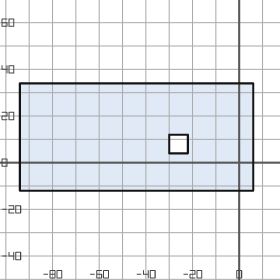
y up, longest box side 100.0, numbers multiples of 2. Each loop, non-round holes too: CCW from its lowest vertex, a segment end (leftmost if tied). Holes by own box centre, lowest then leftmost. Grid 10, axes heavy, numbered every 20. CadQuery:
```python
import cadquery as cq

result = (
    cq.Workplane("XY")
    .moveTo(-94.0, -12.0)
    .lineTo(6.0, -12.0)
    .lineTo(6.0, 34.0)
    .lineTo(-94.0, 34.0)
    .close()
    .moveTo(-30.0, 4.0)
    .lineTo(-22.0, 4.0)
    .lineTo(-22.0, 12.0)
    .lineTo(-30.0, 12.0)
    .close()
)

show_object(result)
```